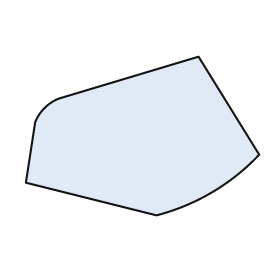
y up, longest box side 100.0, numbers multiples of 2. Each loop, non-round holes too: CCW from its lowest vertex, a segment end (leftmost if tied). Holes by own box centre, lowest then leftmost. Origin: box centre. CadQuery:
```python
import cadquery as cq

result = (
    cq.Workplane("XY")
    .moveTo(6.0, -34.0)
    .threePointArc((30.0, -24.0), (50.0, -8.0))
    .lineTo(24.0, 34.0)
    .lineTo(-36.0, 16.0)
    .threePointArc((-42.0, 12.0), (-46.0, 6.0))
    .lineTo(-50.0, -20.0)
    .close()
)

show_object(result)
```